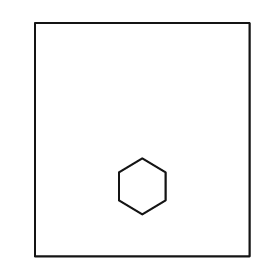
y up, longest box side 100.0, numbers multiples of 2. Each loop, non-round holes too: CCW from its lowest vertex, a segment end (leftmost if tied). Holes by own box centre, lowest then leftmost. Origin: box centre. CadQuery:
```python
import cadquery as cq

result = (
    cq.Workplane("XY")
    .moveTo(-46.0, -50.0)
    .lineTo(46.0, -50.0)
    .lineTo(46.0, 50.0)
    .lineTo(-46.0, 50.0)
    .close()
    .moveTo(0.0, -32.0)
    .lineTo(10.0, -26.0)
    .lineTo(10.0, -14.0)
    .lineTo(0.0, -8.0)
    .lineTo(-10.0, -14.0)
    .lineTo(-10.0, -26.0)
    .close()
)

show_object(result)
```